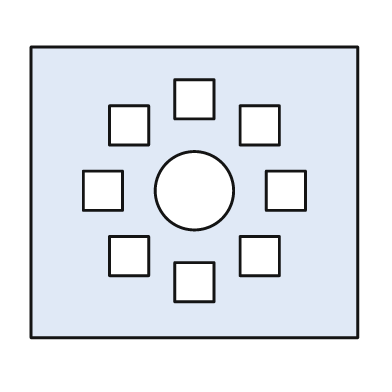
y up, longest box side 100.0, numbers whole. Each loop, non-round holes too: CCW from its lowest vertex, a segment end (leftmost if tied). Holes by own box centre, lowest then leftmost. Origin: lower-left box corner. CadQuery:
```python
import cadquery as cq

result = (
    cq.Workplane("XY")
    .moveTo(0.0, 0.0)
    .lineTo(100.0, 0.0)
    .lineTo(100.0, 89.0)
    .lineTo(0.0, 89.0)
    .close()
    .moveTo(44.0, 11.0)
    .lineTo(56.0, 11.0)
    .lineTo(56.0, 23.0)
    .lineTo(44.0, 23.0)
    .close()
    .moveTo(24.0, 19.0)
    .lineTo(36.0, 19.0)
    .lineTo(36.0, 31.0)
    .lineTo(24.0, 31.0)
    .close()
    .moveTo(64.0, 19.0)
    .lineTo(76.0, 19.0)
    .lineTo(76.0, 31.0)
    .lineTo(64.0, 31.0)
    .close()
    .moveTo(16.0, 39.0)
    .lineTo(28.0, 39.0)
    .lineTo(28.0, 51.0)
    .lineTo(16.0, 51.0)
    .close()
    .moveTo(50.0, 45.0)
    .circle(12.0)
    .moveTo(72.0, 39.0)
    .lineTo(84.0, 39.0)
    .lineTo(84.0, 51.0)
    .lineTo(72.0, 51.0)
    .close()
    .moveTo(24.0, 59.0)
    .lineTo(36.0, 59.0)
    .lineTo(36.0, 71.0)
    .lineTo(24.0, 71.0)
    .close()
    .moveTo(64.0, 59.0)
    .lineTo(76.0, 59.0)
    .lineTo(76.0, 71.0)
    .lineTo(64.0, 71.0)
    .close()
    .moveTo(44.0, 67.0)
    .lineTo(56.0, 67.0)
    .lineTo(56.0, 79.0)
    .lineTo(44.0, 79.0)
    .close()
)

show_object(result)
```